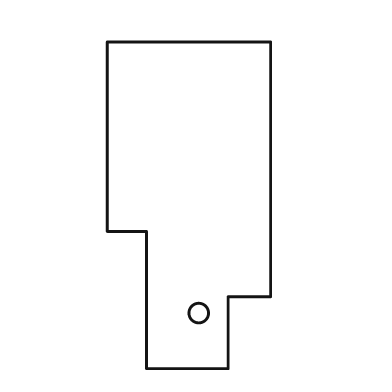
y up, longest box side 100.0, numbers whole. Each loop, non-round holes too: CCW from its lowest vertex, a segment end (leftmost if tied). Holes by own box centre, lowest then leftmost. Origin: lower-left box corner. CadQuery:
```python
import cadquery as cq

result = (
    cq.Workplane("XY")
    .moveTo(12.0, 0.0)
    .lineTo(37.0, 0.0)
    .lineTo(37.0, 22.0)
    .lineTo(50.0, 22.0)
    .lineTo(50.0, 100.0)
    .lineTo(0.0, 100.0)
    .lineTo(0.0, 42.0)
    .lineTo(12.0, 42.0)
    .close()
    .moveTo(28.0, 17.0)
    .circle(3.0)
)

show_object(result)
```